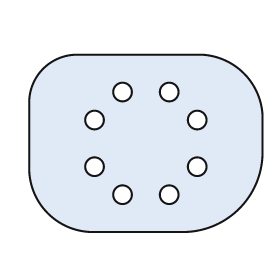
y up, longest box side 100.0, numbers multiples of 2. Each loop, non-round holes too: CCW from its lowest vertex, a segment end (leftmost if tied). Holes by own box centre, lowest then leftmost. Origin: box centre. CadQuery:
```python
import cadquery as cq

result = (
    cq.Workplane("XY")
    .moveTo(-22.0, -38.0)
    .lineTo(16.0, -38.0)
    .threePointArc((40.0, -28.0), (50.0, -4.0))
    .lineTo(50.0, 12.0)
    .threePointArc((42.0, 30.0), (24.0, 38.0))
    .lineTo(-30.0, 38.0)
    .threePointArc((-44.0, 32.0), (-50.0, 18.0))
    .lineTo(-50.0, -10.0)
    .threePointArc((-42.0, -30.0), (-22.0, -38.0))
    .close()
    .moveTo(-10.0, -22.0)
    .circle(4.0)
    .moveTo(10.0, -22.0)
    .circle(4.0)
    .moveTo(-22.0, -10.0)
    .circle(4.0)
    .moveTo(22.0, -10.0)
    .circle(4.0)
    .moveTo(-22.0, 10.0)
    .circle(4.0)
    .moveTo(22.0, 10.0)
    .circle(4.0)
    .moveTo(-10.0, 22.0)
    .circle(4.0)
    .moveTo(10.0, 22.0)
    .circle(4.0)
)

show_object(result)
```